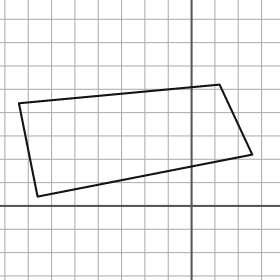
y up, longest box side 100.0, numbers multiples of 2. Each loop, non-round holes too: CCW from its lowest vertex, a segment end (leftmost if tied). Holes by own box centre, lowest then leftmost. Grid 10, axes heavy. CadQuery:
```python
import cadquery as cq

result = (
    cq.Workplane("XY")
    .moveTo(-66.0, 4.0)
    .lineTo(26.0, 22.0)
    .lineTo(12.0, 52.0)
    .lineTo(-74.0, 44.0)
    .close()
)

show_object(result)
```